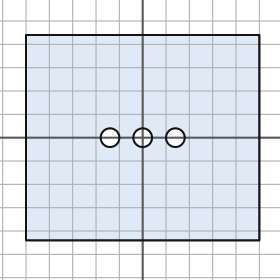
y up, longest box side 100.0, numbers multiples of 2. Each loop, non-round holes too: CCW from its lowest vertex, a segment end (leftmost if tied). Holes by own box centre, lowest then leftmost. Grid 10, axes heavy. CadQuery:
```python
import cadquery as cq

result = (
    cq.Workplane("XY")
    .moveTo(-50.0, -44.0)
    .lineTo(50.0, -44.0)
    .lineTo(50.0, 44.0)
    .lineTo(-50.0, 44.0)
    .close()
    .moveTo(-14.0, 0.0)
    .circle(4.0)
    .moveTo(0.0, 0.0)
    .circle(4.0)
    .moveTo(14.0, 0.0)
    .circle(4.0)
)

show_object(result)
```